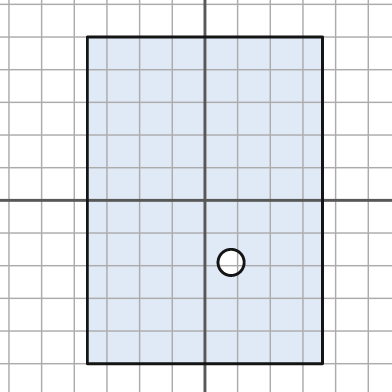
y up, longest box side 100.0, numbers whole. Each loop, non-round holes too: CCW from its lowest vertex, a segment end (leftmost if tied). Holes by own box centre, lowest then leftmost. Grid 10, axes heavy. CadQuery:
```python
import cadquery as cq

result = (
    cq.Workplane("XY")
    .moveTo(-36.0, -50.0)
    .lineTo(36.0, -50.0)
    .lineTo(36.0, 50.0)
    .lineTo(-36.0, 50.0)
    .close()
    .moveTo(8.0, -19.0)
    .circle(4.0)
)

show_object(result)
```